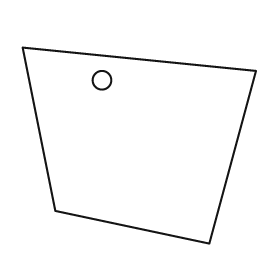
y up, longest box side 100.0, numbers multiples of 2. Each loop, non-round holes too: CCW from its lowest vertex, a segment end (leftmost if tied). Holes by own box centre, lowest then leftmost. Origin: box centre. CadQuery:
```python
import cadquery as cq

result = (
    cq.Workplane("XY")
    .moveTo(30.0, -42.0)
    .lineTo(50.0, 32.0)
    .lineTo(-50.0, 42.0)
    .lineTo(-36.0, -28.0)
    .close()
    .moveTo(-16.0, 28.0)
    .circle(4.0)
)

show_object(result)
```